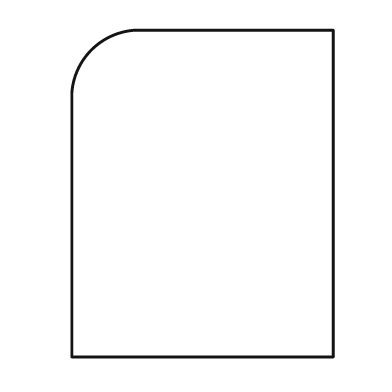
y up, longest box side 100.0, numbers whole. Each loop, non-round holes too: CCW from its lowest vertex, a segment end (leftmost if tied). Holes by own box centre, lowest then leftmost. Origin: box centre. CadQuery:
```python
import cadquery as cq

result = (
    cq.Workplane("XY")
    .moveTo(-40.0, -50.0)
    .lineTo(40.0, -50.0)
    .lineTo(40.0, 50.0)
    .lineTo(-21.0, 50.0)
    .threePointArc((-34.0, 44.0), (-40.0, 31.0))
    .close()
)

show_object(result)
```